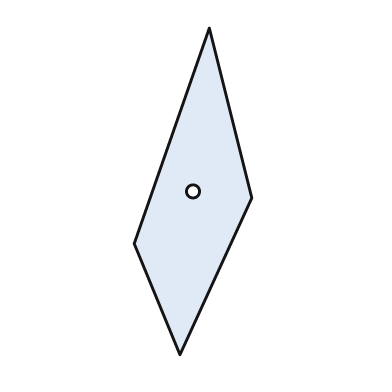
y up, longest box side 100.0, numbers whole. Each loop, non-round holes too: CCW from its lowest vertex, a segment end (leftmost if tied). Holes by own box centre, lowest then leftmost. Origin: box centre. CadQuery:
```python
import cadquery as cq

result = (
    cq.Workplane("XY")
    .moveTo(-4.0, -50.0)
    .lineTo(18.0, -2.0)
    .lineTo(5.0, 50.0)
    .lineTo(-18.0, -16.0)
    .close()
    .moveTo(0.0, 0.0)
    .circle(2.0)
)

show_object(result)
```